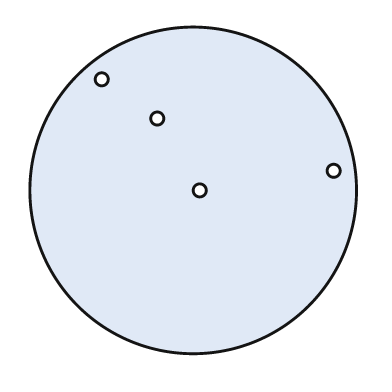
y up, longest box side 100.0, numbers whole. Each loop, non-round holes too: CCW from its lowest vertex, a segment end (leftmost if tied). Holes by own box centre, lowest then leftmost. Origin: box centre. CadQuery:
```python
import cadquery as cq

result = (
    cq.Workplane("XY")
    .moveTo(0.0, 0.0)
    .circle(50.0)
    .moveTo(2.0, 0.0)
    .circle(2.0)
    .moveTo(43.0, 6.0)
    .circle(2.0)
    .moveTo(-11.0, 22.0)
    .circle(2.0)
    .moveTo(-28.0, 34.0)
    .circle(2.0)
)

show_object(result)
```